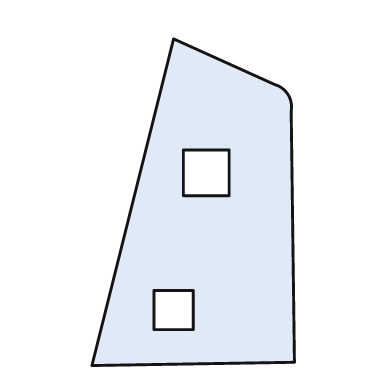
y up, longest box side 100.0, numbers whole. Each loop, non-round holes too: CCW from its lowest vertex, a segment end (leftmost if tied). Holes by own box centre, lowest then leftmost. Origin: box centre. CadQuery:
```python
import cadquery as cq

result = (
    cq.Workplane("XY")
    .moveTo(-31.0, -50.0)
    .lineTo(31.0, -49.0)
    .lineTo(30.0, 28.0)
    .threePointArc((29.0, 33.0), (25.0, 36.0))
    .lineTo(-6.0, 50.0)
    .close()
    .moveTo(-12.0, -39.0)
    .lineTo(0.0, -39.0)
    .lineTo(0.0, -27.0)
    .lineTo(-12.0, -27.0)
    .close()
    .moveTo(-3.0, 2.0)
    .lineTo(11.0, 2.0)
    .lineTo(11.0, 16.0)
    .lineTo(-3.0, 16.0)
    .close()
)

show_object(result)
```